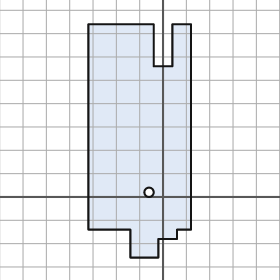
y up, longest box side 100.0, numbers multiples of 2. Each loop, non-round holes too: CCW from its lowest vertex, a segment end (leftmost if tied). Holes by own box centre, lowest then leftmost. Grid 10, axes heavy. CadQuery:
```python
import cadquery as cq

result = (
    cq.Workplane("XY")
    .moveTo(-14.0, -26.0)
    .lineTo(-2.0, -26.0)
    .lineTo(-2.0, -18.0)
    .lineTo(6.0, -18.0)
    .lineTo(6.0, -14.0)
    .lineTo(12.0, -14.0)
    .lineTo(12.0, 74.0)
    .lineTo(4.0, 74.0)
    .lineTo(4.0, 56.0)
    .lineTo(-4.0, 56.0)
    .lineTo(-4.0, 74.0)
    .lineTo(-32.0, 74.0)
    .lineTo(-32.0, -14.0)
    .lineTo(-14.0, -14.0)
    .close()
    .moveTo(-6.0, 2.0)
    .circle(2.0)
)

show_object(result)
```